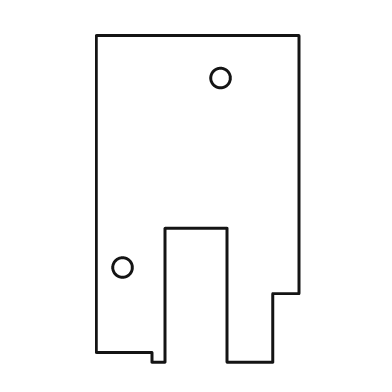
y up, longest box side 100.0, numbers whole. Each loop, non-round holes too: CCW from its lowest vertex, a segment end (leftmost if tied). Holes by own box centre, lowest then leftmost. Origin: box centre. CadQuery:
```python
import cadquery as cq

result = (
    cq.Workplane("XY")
    .moveTo(-14.0, -50.0)
    .lineTo(-10.0, -50.0)
    .lineTo(-10.0, -9.0)
    .lineTo(9.0, -9.0)
    .lineTo(9.0, -50.0)
    .lineTo(23.0, -50.0)
    .lineTo(23.0, -29.0)
    .lineTo(31.0, -29.0)
    .lineTo(31.0, 50.0)
    .lineTo(-31.0, 50.0)
    .lineTo(-31.0, -47.0)
    .lineTo(-14.0, -47.0)
    .close()
    .moveTo(-23.0, -21.0)
    .circle(3.0)
    .moveTo(7.0, 37.0)
    .circle(3.0)
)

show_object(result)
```